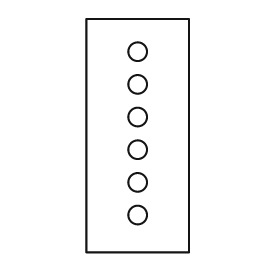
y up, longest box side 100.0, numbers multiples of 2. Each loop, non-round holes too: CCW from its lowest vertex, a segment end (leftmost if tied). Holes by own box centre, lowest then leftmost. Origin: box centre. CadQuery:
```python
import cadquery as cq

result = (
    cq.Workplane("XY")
    .moveTo(-22.0, -50.0)
    .lineTo(22.0, -50.0)
    .lineTo(22.0, 50.0)
    .lineTo(-22.0, 50.0)
    .close()
    .moveTo(0.0, -34.0)
    .circle(4.0)
    .moveTo(0.0, -20.0)
    .circle(4.0)
    .moveTo(0.0, -6.0)
    .circle(4.0)
    .moveTo(0.0, 8.0)
    .circle(4.0)
    .moveTo(0.0, 22.0)
    .circle(4.0)
    .moveTo(0.0, 36.0)
    .circle(4.0)
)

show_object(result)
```